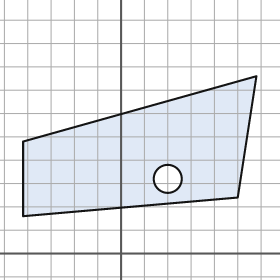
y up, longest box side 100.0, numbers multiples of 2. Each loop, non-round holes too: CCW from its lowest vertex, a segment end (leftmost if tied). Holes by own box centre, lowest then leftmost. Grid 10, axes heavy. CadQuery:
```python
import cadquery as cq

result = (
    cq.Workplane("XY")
    .moveTo(-42.0, 16.0)
    .lineTo(50.0, 24.0)
    .lineTo(58.0, 76.0)
    .lineTo(-42.0, 48.0)
    .close()
    .moveTo(20.0, 32.0)
    .circle(6.0)
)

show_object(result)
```